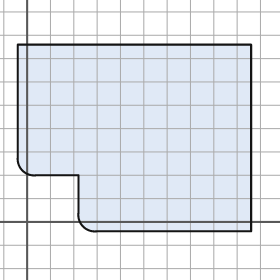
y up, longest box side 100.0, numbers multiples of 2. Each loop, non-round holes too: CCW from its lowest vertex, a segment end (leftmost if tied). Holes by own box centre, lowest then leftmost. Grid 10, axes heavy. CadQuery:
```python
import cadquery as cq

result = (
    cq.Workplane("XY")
    .moveTo(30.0, -4.0)
    .lineTo(96.0, -4.0)
    .lineTo(96.0, 76.0)
    .lineTo(-4.0, 76.0)
    .lineTo(-4.0, 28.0)
    .threePointArc((-2.0, 22.0), (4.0, 20.0))
    .lineTo(22.0, 20.0)
    .lineTo(22.0, 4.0)
    .threePointArc((24.0, -2.0), (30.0, -4.0))
    .close()
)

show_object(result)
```